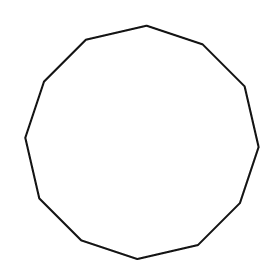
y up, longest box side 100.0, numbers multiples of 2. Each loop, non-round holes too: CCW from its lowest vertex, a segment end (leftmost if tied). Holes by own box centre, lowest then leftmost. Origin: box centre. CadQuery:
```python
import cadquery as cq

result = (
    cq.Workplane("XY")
    .moveTo(-2.0, -50.0)
    .lineTo(24.0, -44.0)
    .lineTo(42.0, -26.0)
    .lineTo(50.0, -2.0)
    .lineTo(44.0, 24.0)
    .lineTo(26.0, 42.0)
    .lineTo(2.0, 50.0)
    .lineTo(-24.0, 44.0)
    .lineTo(-42.0, 26.0)
    .lineTo(-50.0, 2.0)
    .lineTo(-44.0, -24.0)
    .lineTo(-26.0, -42.0)
    .close()
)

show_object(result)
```